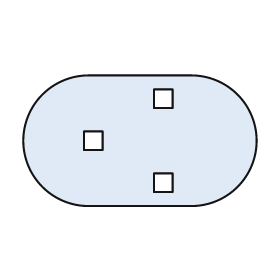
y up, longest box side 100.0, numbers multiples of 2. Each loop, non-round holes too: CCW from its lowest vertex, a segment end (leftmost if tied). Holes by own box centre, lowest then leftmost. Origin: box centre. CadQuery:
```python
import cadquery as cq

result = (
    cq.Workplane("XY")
    .moveTo(-22.0, -28.0)
    .lineTo(22.0, -28.0)
    .threePointArc((50.0, 0.0), (22.0, 28.0))
    .lineTo(-22.0, 28.0)
    .threePointArc((-50.0, 0.0), (-22.0, -28.0))
    .close()
    .moveTo(6.0, -22.0)
    .lineTo(14.0, -22.0)
    .lineTo(14.0, -14.0)
    .lineTo(6.0, -14.0)
    .close()
    .moveTo(-24.0, -4.0)
    .lineTo(-16.0, -4.0)
    .lineTo(-16.0, 4.0)
    .lineTo(-24.0, 4.0)
    .close()
    .moveTo(6.0, 14.0)
    .lineTo(14.0, 14.0)
    .lineTo(14.0, 22.0)
    .lineTo(6.0, 22.0)
    .close()
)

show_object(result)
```